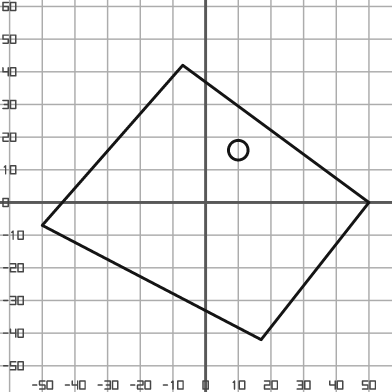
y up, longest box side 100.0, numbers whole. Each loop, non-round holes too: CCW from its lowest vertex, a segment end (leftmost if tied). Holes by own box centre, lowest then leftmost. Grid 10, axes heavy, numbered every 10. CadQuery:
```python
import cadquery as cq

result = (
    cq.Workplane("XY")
    .moveTo(17.0, -42.0)
    .lineTo(50.0, 0.0)
    .lineTo(-7.0, 42.0)
    .lineTo(-50.0, -7.0)
    .close()
    .moveTo(10.0, 16.0)
    .circle(3.0)
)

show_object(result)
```